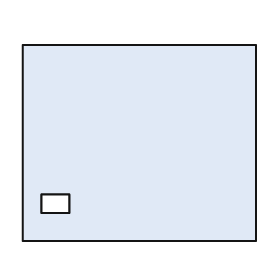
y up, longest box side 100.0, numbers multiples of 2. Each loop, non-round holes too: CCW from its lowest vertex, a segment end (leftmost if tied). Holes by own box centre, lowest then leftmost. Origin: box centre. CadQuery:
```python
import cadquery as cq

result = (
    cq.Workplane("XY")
    .moveTo(-50.0, -42.0)
    .lineTo(50.0, -42.0)
    .lineTo(50.0, 42.0)
    .lineTo(-50.0, 42.0)
    .close()
    .moveTo(-42.0, -30.0)
    .lineTo(-30.0, -30.0)
    .lineTo(-30.0, -22.0)
    .lineTo(-42.0, -22.0)
    .close()
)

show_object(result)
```